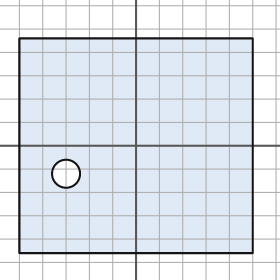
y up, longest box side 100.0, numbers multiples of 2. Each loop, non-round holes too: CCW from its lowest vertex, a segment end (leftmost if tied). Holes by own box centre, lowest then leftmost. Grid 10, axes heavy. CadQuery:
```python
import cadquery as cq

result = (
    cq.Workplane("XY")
    .moveTo(-50.0, -46.0)
    .lineTo(50.0, -46.0)
    .lineTo(50.0, 46.0)
    .lineTo(-50.0, 46.0)
    .close()
    .moveTo(-30.0, -12.0)
    .circle(6.0)
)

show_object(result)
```